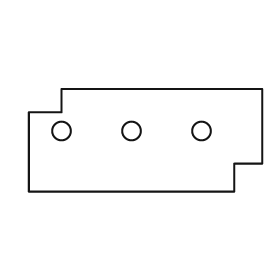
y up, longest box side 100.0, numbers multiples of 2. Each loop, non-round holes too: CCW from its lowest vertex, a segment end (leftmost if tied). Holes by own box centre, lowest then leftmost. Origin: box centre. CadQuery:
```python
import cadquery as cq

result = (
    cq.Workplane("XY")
    .moveTo(-50.0, -22.0)
    .lineTo(38.0, -22.0)
    .lineTo(38.0, -10.0)
    .lineTo(50.0, -10.0)
    .lineTo(50.0, 22.0)
    .lineTo(-36.0, 22.0)
    .lineTo(-36.0, 12.0)
    .lineTo(-50.0, 12.0)
    .close()
    .moveTo(-36.0, 4.0)
    .circle(4.0)
    .moveTo(-6.0, 4.0)
    .circle(4.0)
    .moveTo(24.0, 4.0)
    .circle(4.0)
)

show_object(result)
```